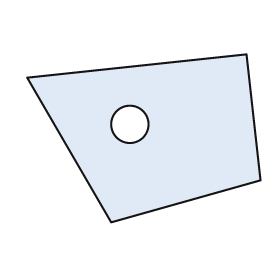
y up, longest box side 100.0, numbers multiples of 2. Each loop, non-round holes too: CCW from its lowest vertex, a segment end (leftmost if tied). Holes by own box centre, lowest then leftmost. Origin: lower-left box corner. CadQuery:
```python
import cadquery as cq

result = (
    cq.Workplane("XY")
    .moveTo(36.0, 0.0)
    .lineTo(100.0, 18.0)
    .lineTo(94.0, 72.0)
    .lineTo(0.0, 62.0)
    .close()
    .moveTo(44.0, 42.0)
    .circle(8.0)
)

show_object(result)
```